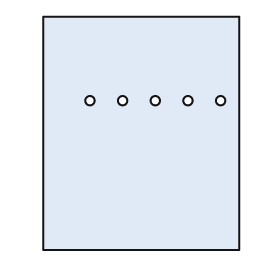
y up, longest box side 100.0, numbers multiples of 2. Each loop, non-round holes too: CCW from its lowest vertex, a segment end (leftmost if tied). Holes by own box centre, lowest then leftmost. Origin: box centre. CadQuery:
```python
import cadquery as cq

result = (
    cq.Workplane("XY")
    .moveTo(-42.0, -50.0)
    .lineTo(42.0, -50.0)
    .lineTo(42.0, 50.0)
    .lineTo(-42.0, 50.0)
    .close()
    .moveTo(-22.0, 14.0)
    .circle(2.0)
    .moveTo(-8.0, 14.0)
    .circle(2.0)
    .moveTo(6.0, 14.0)
    .circle(2.0)
    .moveTo(20.0, 14.0)
    .circle(2.0)
    .moveTo(34.0, 14.0)
    .circle(2.0)
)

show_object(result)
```